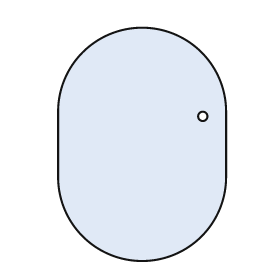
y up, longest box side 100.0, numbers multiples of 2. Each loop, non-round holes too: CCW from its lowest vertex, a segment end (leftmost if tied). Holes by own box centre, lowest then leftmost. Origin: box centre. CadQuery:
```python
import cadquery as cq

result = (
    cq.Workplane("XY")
    .moveTo(-36.0, -14.0)
    .threePointArc((0.0, -50.0), (36.0, -14.0))
    .lineTo(36.0, 14.0)
    .threePointArc((0.0, 50.0), (-36.0, 14.0))
    .close()
    .moveTo(26.0, 12.0)
    .circle(2.0)
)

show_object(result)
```